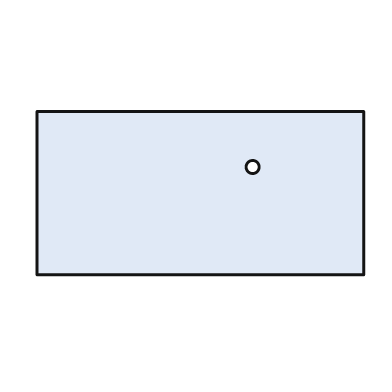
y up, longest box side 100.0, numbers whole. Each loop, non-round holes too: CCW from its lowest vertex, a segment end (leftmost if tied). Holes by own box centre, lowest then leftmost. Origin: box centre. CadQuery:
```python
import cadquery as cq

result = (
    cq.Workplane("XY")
    .moveTo(-50.0, -25.0)
    .lineTo(50.0, -25.0)
    .lineTo(50.0, 25.0)
    .lineTo(-50.0, 25.0)
    .close()
    .moveTo(16.0, 8.0)
    .circle(2.0)
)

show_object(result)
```